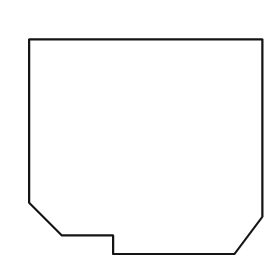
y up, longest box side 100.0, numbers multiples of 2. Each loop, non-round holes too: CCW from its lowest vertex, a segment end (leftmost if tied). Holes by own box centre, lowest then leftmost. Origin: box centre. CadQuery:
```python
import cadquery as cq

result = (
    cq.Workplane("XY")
    .moveTo(-14.0, -46.0)
    .lineTo(38.0, -46.0)
    .lineTo(50.0, -30.0)
    .lineTo(50.0, 46.0)
    .lineTo(-50.0, 46.0)
    .lineTo(-50.0, -24.0)
    .lineTo(-36.0, -38.0)
    .lineTo(-14.0, -38.0)
    .close()
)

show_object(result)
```